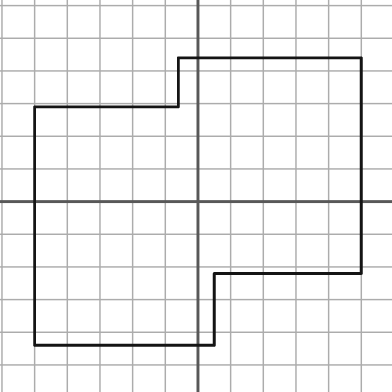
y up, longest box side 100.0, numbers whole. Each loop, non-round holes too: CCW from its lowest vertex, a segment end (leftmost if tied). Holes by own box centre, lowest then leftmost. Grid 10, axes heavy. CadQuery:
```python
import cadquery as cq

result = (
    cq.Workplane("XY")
    .moveTo(-50.0, -44.0)
    .lineTo(5.0, -44.0)
    .lineTo(5.0, -22.0)
    .lineTo(50.0, -22.0)
    .lineTo(50.0, 44.0)
    .lineTo(-6.0, 44.0)
    .lineTo(-6.0, 29.0)
    .lineTo(-50.0, 29.0)
    .close()
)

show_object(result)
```